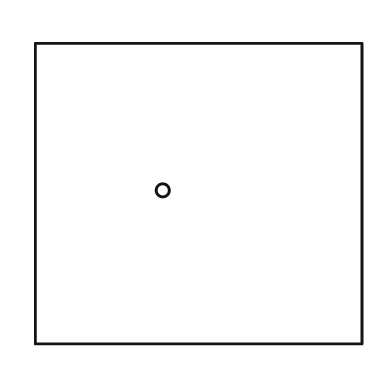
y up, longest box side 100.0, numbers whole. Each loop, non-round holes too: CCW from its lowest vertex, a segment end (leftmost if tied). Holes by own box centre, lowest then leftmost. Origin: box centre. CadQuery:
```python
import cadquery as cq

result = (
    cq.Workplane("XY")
    .moveTo(-50.0, -46.0)
    .lineTo(50.0, -46.0)
    .lineTo(50.0, 46.0)
    .lineTo(-50.0, 46.0)
    .close()
    .moveTo(-11.0, 1.0)
    .circle(2.0)
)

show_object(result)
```